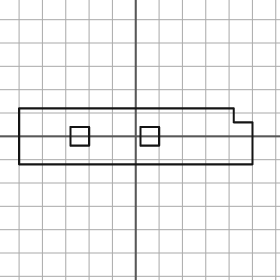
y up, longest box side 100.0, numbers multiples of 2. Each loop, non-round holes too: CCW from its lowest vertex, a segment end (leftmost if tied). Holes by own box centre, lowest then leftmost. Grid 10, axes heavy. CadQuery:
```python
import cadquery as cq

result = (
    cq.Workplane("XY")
    .moveTo(-50.0, -12.0)
    .lineTo(50.0, -12.0)
    .lineTo(50.0, 6.0)
    .lineTo(42.0, 6.0)
    .lineTo(42.0, 12.0)
    .lineTo(-50.0, 12.0)
    .close()
    .moveTo(-28.0, -4.0)
    .lineTo(-20.0, -4.0)
    .lineTo(-20.0, 4.0)
    .lineTo(-28.0, 4.0)
    .close()
    .moveTo(2.0, -4.0)
    .lineTo(10.0, -4.0)
    .lineTo(10.0, 4.0)
    .lineTo(2.0, 4.0)
    .close()
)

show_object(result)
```